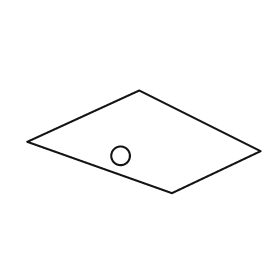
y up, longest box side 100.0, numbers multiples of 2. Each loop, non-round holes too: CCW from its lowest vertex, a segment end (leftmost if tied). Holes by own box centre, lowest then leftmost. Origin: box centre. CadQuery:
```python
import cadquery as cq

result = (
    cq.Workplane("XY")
    .moveTo(12.0, -22.0)
    .lineTo(50.0, -4.0)
    .lineTo(-2.0, 22.0)
    .lineTo(-50.0, 0.0)
    .close()
    .moveTo(-10.0, -6.0)
    .circle(4.0)
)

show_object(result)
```